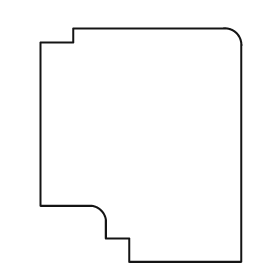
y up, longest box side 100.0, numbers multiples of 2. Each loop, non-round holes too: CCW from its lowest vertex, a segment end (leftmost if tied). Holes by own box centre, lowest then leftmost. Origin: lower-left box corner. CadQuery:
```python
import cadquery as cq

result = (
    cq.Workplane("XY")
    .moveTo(38.0, 0.0)
    .lineTo(86.0, 0.0)
    .lineTo(86.0, 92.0)
    .threePointArc((84.0, 98.0), (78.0, 100.0))
    .lineTo(14.0, 100.0)
    .lineTo(14.0, 94.0)
    .lineTo(0.0, 94.0)
    .lineTo(0.0, 24.0)
    .lineTo(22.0, 24.0)
    .threePointArc((26.0, 22.0), (28.0, 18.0))
    .lineTo(28.0, 10.0)
    .lineTo(38.0, 10.0)
    .close()
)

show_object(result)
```